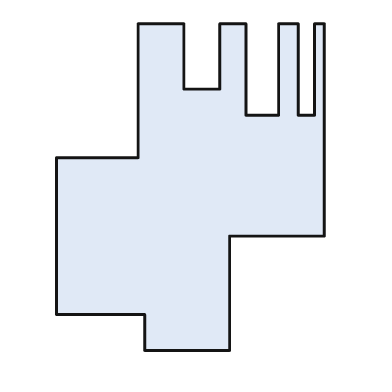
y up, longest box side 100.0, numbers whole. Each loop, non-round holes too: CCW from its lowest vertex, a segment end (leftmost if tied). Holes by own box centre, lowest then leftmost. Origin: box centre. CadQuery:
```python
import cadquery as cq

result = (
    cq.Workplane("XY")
    .moveTo(-14.0, -50.0)
    .lineTo(12.0, -50.0)
    .lineTo(12.0, -15.0)
    .lineTo(41.0, -15.0)
    .lineTo(41.0, 50.0)
    .lineTo(38.0, 50.0)
    .lineTo(38.0, 22.0)
    .lineTo(33.0, 22.0)
    .lineTo(33.0, 50.0)
    .lineTo(27.0, 50.0)
    .lineTo(27.0, 22.0)
    .lineTo(17.0, 22.0)
    .lineTo(17.0, 50.0)
    .lineTo(9.0, 50.0)
    .lineTo(9.0, 30.0)
    .lineTo(-2.0, 30.0)
    .lineTo(-2.0, 50.0)
    .lineTo(-16.0, 50.0)
    .lineTo(-16.0, 9.0)
    .lineTo(-41.0, 9.0)
    .lineTo(-41.0, -39.0)
    .lineTo(-14.0, -39.0)
    .close()
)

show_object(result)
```